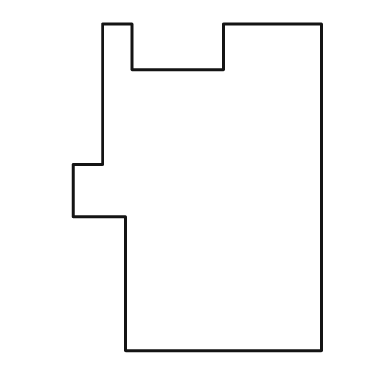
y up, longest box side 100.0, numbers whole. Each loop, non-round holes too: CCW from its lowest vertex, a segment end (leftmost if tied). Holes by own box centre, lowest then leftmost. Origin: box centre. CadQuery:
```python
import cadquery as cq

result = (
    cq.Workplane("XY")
    .moveTo(-22.0, -50.0)
    .lineTo(38.0, -50.0)
    .lineTo(38.0, 50.0)
    .lineTo(8.0, 50.0)
    .lineTo(8.0, 36.0)
    .lineTo(-20.0, 36.0)
    .lineTo(-20.0, 50.0)
    .lineTo(-29.0, 50.0)
    .lineTo(-29.0, 7.0)
    .lineTo(-38.0, 7.0)
    .lineTo(-38.0, -9.0)
    .lineTo(-22.0, -9.0)
    .close()
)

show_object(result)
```